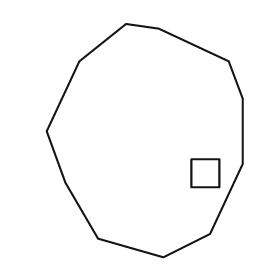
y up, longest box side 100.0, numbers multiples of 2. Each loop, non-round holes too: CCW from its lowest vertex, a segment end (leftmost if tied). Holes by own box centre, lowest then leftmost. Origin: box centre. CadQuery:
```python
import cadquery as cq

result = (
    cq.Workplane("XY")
    .moveTo(8.0, -50.0)
    .lineTo(28.0, -40.0)
    .lineTo(42.0, -10.0)
    .lineTo(42.0, 18.0)
    .lineTo(36.0, 34.0)
    .lineTo(6.0, 48.0)
    .lineTo(-8.0, 50.0)
    .lineTo(-28.0, 34.0)
    .lineTo(-42.0, 4.0)
    .lineTo(-34.0, -18.0)
    .lineTo(-20.0, -42.0)
    .close()
    .moveTo(20.0, -20.0)
    .lineTo(32.0, -20.0)
    .lineTo(32.0, -8.0)
    .lineTo(20.0, -8.0)
    .close()
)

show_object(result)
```